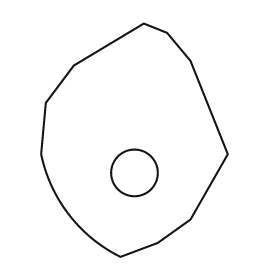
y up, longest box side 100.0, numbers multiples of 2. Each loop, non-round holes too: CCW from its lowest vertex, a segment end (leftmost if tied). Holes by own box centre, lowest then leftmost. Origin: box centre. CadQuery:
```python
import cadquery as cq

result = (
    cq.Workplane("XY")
    .moveTo(-6.0, -50.0)
    .lineTo(10.0, -44.0)
    .lineTo(24.0, -34.0)
    .lineTo(40.0, -6.0)
    .lineTo(24.0, 34.0)
    .lineTo(14.0, 46.0)
    .lineTo(4.0, 50.0)
    .lineTo(-26.0, 32.0)
    .lineTo(-38.0, 16.0)
    .lineTo(-40.0, -6.0)
    .threePointArc((-28.0, -32.0), (-6.0, -50.0))
    .close()
    .moveTo(0.0, -14.0)
    .circle(10.0)
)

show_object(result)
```